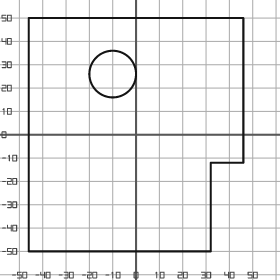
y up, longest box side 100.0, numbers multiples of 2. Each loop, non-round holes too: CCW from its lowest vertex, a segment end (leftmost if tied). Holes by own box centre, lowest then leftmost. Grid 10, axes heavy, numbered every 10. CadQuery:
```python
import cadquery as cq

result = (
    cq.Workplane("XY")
    .moveTo(-46.0, -50.0)
    .lineTo(32.0, -50.0)
    .lineTo(32.0, -12.0)
    .lineTo(46.0, -12.0)
    .lineTo(46.0, 50.0)
    .lineTo(-46.0, 50.0)
    .close()
    .moveTo(-10.0, 26.0)
    .circle(10.0)
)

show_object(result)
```